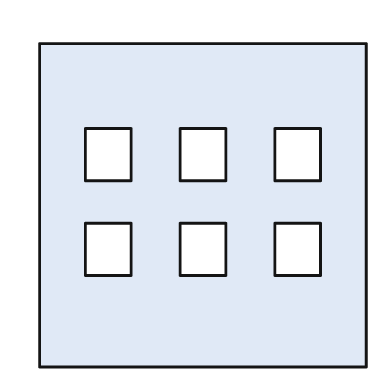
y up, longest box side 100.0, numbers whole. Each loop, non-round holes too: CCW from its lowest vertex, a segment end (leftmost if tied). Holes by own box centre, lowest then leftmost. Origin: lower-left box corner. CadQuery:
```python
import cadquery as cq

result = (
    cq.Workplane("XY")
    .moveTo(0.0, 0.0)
    .lineTo(100.0, 0.0)
    .lineTo(100.0, 99.0)
    .lineTo(0.0, 99.0)
    .close()
    .moveTo(14.0, 28.0)
    .lineTo(28.0, 28.0)
    .lineTo(28.0, 44.0)
    .lineTo(14.0, 44.0)
    .close()
    .moveTo(43.0, 28.0)
    .lineTo(57.0, 28.0)
    .lineTo(57.0, 44.0)
    .lineTo(43.0, 44.0)
    .close()
    .moveTo(72.0, 28.0)
    .lineTo(86.0, 28.0)
    .lineTo(86.0, 44.0)
    .lineTo(72.0, 44.0)
    .close()
    .moveTo(14.0, 57.0)
    .lineTo(28.0, 57.0)
    .lineTo(28.0, 73.0)
    .lineTo(14.0, 73.0)
    .close()
    .moveTo(43.0, 57.0)
    .lineTo(57.0, 57.0)
    .lineTo(57.0, 73.0)
    .lineTo(43.0, 73.0)
    .close()
    .moveTo(72.0, 57.0)
    .lineTo(86.0, 57.0)
    .lineTo(86.0, 73.0)
    .lineTo(72.0, 73.0)
    .close()
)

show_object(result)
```